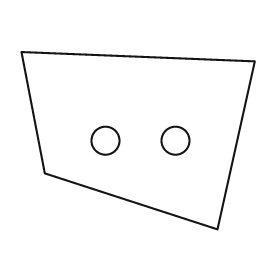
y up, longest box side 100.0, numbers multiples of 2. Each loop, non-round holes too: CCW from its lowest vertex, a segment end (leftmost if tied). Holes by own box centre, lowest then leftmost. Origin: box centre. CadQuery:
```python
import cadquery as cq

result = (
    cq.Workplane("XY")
    .moveTo(34.0, -38.0)
    .lineTo(50.0, 34.0)
    .lineTo(-50.0, 38.0)
    .lineTo(-40.0, -14.0)
    .close()
    .moveTo(-14.0, 0.0)
    .circle(6.0)
    .moveTo(16.0, 0.0)
    .circle(6.0)
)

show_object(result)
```